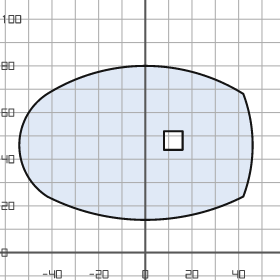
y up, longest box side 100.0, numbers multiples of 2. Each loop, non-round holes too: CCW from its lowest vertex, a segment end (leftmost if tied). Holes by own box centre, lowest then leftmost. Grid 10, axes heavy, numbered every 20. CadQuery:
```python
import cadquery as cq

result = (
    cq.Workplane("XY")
    .moveTo(-42.0, 24.0)
    .threePointArc((0.0, 14.0), (42.0, 24.0))
    .threePointArc((46.0, 46.0), (42.0, 68.0))
    .threePointArc((0.0, 80.0), (-42.0, 68.0))
    .threePointArc((-54.0, 46.0), (-42.0, 24.0))
    .close()
    .moveTo(8.0, 44.0)
    .lineTo(16.0, 44.0)
    .lineTo(16.0, 52.0)
    .lineTo(8.0, 52.0)
    .close()
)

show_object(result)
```